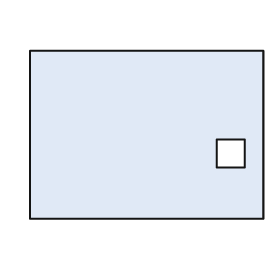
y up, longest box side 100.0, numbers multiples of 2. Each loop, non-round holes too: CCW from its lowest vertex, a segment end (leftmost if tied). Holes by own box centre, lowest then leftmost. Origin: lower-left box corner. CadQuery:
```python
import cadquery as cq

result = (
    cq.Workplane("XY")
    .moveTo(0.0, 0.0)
    .lineTo(100.0, 0.0)
    .lineTo(100.0, 72.0)
    .lineTo(0.0, 72.0)
    .close()
    .moveTo(80.0, 22.0)
    .lineTo(92.0, 22.0)
    .lineTo(92.0, 34.0)
    .lineTo(80.0, 34.0)
    .close()
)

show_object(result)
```